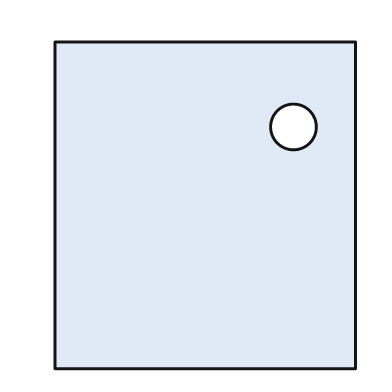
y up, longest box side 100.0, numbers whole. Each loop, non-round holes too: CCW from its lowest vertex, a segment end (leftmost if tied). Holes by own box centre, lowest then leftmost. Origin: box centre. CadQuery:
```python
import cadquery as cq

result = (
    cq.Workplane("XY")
    .moveTo(-46.0, -50.0)
    .lineTo(46.0, -50.0)
    .lineTo(46.0, 50.0)
    .lineTo(-46.0, 50.0)
    .close()
    .moveTo(27.0, 24.0)
    .circle(7.0)
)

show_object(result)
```